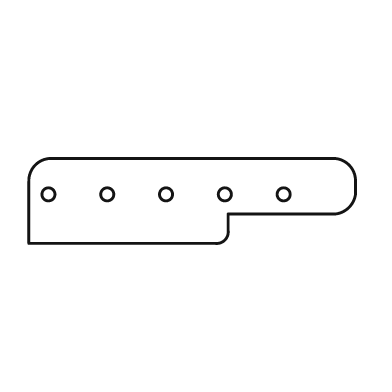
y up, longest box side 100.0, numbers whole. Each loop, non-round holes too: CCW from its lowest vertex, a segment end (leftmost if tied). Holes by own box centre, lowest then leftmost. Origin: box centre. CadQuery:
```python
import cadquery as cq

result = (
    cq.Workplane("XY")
    .moveTo(-50.0, -13.0)
    .lineTo(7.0, -13.0)
    .threePointArc((10.0, -12.0), (11.0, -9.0))
    .lineTo(11.0, -4.0)
    .lineTo(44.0, -4.0)
    .threePointArc((48.0, -2.0), (50.0, 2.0))
    .lineTo(50.0, 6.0)
    .threePointArc((48.0, 11.0), (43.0, 13.0))
    .lineTo(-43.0, 13.0)
    .threePointArc((-48.0, 11.0), (-50.0, 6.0))
    .close()
    .moveTo(-44.0, 2.0)
    .circle(2.0)
    .moveTo(-26.0, 2.0)
    .circle(2.0)
    .moveTo(-8.0, 2.0)
    .circle(2.0)
    .moveTo(10.0, 2.0)
    .circle(2.0)
    .moveTo(28.0, 2.0)
    .circle(2.0)
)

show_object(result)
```